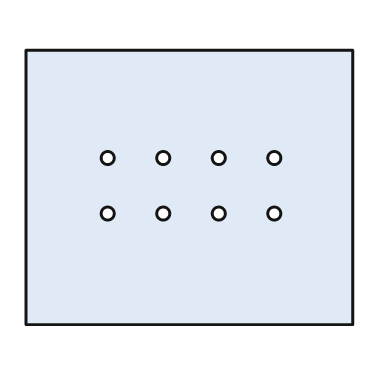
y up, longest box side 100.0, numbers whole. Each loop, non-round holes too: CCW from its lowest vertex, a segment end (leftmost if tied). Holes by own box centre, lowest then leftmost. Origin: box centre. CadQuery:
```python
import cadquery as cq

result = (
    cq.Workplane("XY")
    .moveTo(-50.0, -42.0)
    .lineTo(50.0, -42.0)
    .lineTo(50.0, 42.0)
    .lineTo(-50.0, 42.0)
    .close()
    .moveTo(-25.0, -8.0)
    .circle(2.0)
    .moveTo(-8.0, -8.0)
    .circle(2.0)
    .moveTo(9.0, -8.0)
    .circle(2.0)
    .moveTo(26.0, -8.0)
    .circle(2.0)
    .moveTo(-25.0, 9.0)
    .circle(2.0)
    .moveTo(-8.0, 9.0)
    .circle(2.0)
    .moveTo(9.0, 9.0)
    .circle(2.0)
    .moveTo(26.0, 9.0)
    .circle(2.0)
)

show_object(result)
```